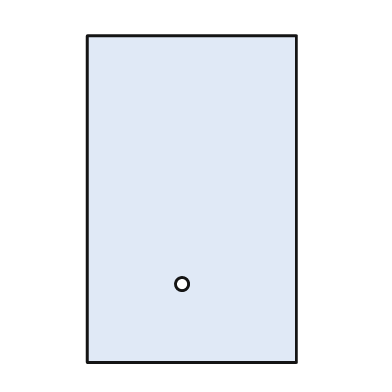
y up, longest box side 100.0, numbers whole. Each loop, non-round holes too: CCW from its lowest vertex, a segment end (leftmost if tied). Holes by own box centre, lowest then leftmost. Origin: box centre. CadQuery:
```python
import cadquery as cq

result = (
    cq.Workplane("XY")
    .moveTo(-32.0, -50.0)
    .lineTo(32.0, -50.0)
    .lineTo(32.0, 50.0)
    .lineTo(-32.0, 50.0)
    .close()
    .moveTo(-3.0, -26.0)
    .circle(2.0)
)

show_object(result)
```